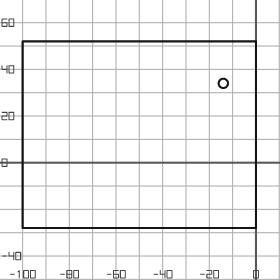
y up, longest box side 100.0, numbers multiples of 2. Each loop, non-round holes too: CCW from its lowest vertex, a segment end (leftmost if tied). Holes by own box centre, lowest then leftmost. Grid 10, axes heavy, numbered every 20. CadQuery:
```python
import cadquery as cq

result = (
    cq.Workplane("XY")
    .moveTo(-100.0, -28.0)
    .lineTo(0.0, -28.0)
    .lineTo(0.0, 52.0)
    .lineTo(-100.0, 52.0)
    .close()
    .moveTo(-14.0, 34.0)
    .circle(2.0)
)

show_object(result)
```